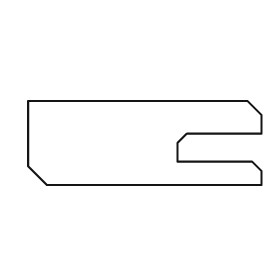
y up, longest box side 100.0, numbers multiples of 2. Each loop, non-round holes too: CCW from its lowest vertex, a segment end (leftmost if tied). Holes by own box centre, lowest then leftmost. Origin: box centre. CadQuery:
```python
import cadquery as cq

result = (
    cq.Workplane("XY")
    .moveTo(-42.0, -18.0)
    .lineTo(50.0, -18.0)
    .lineTo(50.0, -12.0)
    .lineTo(46.0, -8.0)
    .lineTo(14.0, -8.0)
    .lineTo(14.0, 0.0)
    .lineTo(18.0, 4.0)
    .lineTo(50.0, 4.0)
    .lineTo(50.0, 12.0)
    .lineTo(44.0, 18.0)
    .lineTo(-50.0, 18.0)
    .lineTo(-50.0, -10.0)
    .close()
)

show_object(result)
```